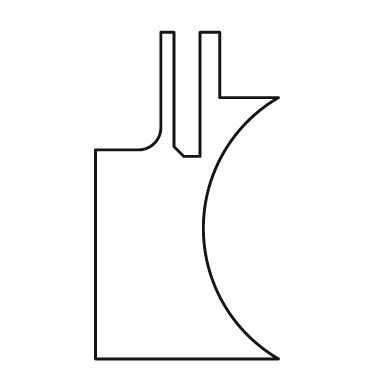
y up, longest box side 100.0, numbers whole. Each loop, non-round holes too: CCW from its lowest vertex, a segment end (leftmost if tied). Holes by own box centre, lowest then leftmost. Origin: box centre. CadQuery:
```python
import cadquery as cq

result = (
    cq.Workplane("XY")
    .moveTo(-28.0, -50.0)
    .lineTo(28.0, -50.0)
    .threePointArc((5.0, -10.0), (28.0, 30.0))
    .lineTo(10.0, 30.0)
    .lineTo(10.0, 50.0)
    .lineTo(4.0, 50.0)
    .lineTo(4.0, 12.0)
    .lineTo(-1.0, 12.0)
    .lineTo(-4.0, 15.0)
    .lineTo(-4.0, 50.0)
    .lineTo(-8.0, 50.0)
    .lineTo(-8.0, 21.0)
    .threePointArc((-10.0, 16.0), (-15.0, 14.0))
    .lineTo(-28.0, 14.0)
    .close()
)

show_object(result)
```